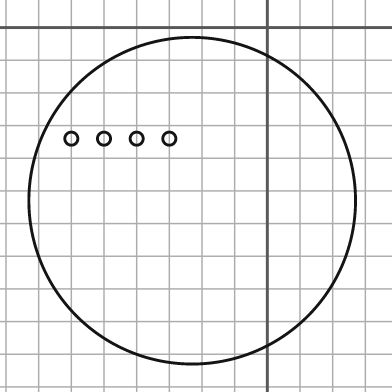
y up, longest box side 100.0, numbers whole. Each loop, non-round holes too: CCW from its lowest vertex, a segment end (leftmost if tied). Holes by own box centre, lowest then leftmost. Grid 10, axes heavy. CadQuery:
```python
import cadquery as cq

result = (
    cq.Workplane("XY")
    .moveTo(-23.0, -53.0)
    .circle(50.0)
    .moveTo(-60.0, -34.0)
    .circle(2.0)
    .moveTo(-50.0, -34.0)
    .circle(2.0)
    .moveTo(-40.0, -34.0)
    .circle(2.0)
    .moveTo(-30.0, -34.0)
    .circle(2.0)
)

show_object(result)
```